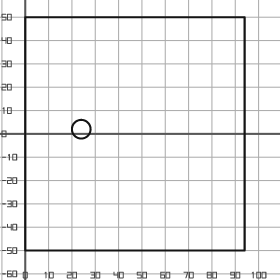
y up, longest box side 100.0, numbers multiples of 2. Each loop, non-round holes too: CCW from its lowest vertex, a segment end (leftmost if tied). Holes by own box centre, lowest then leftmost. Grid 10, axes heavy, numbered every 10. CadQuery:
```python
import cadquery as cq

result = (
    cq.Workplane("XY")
    .moveTo(0.0, -50.0)
    .lineTo(94.0, -50.0)
    .lineTo(94.0, 50.0)
    .lineTo(0.0, 50.0)
    .close()
    .moveTo(24.0, 2.0)
    .circle(4.0)
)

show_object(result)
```